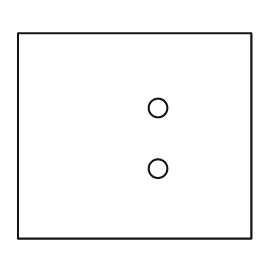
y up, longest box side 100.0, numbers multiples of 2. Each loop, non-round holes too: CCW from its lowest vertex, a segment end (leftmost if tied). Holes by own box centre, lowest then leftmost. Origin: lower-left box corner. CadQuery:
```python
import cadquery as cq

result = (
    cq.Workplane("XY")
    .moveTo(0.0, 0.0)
    .lineTo(100.0, 0.0)
    .lineTo(100.0, 88.0)
    .lineTo(0.0, 88.0)
    .close()
    .moveTo(60.0, 30.0)
    .circle(4.0)
    .moveTo(60.0, 56.0)
    .circle(4.0)
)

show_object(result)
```